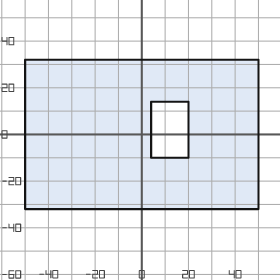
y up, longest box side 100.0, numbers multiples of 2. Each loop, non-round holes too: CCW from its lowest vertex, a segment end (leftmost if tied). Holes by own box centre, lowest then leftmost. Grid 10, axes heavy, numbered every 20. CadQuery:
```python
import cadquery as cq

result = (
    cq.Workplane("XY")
    .moveTo(-50.0, -32.0)
    .lineTo(50.0, -32.0)
    .lineTo(50.0, 32.0)
    .lineTo(-50.0, 32.0)
    .close()
    .moveTo(4.0, -10.0)
    .lineTo(20.0, -10.0)
    .lineTo(20.0, 14.0)
    .lineTo(4.0, 14.0)
    .close()
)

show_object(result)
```